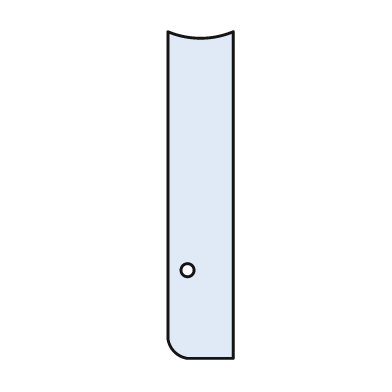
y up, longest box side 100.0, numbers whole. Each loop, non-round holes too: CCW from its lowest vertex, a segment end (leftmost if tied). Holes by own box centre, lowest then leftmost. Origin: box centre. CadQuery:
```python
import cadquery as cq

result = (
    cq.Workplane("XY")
    .moveTo(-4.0, -50.0)
    .lineTo(10.0, -50.0)
    .lineTo(10.0, 50.0)
    .threePointArc((0.0, 48.0), (-10.0, 50.0))
    .lineTo(-10.0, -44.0)
    .threePointArc((-8.0, -48.0), (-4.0, -50.0))
    .close()
    .moveTo(-4.0, -23.0)
    .circle(2.0)
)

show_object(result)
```